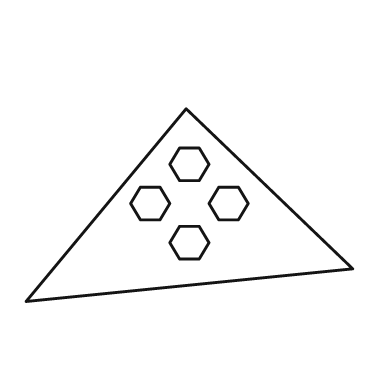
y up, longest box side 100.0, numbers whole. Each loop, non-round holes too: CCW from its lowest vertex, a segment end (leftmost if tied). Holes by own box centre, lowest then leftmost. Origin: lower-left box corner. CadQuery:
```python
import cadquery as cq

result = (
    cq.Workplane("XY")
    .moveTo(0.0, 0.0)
    .lineTo(100.0, 10.0)
    .lineTo(49.0, 59.0)
    .close()
    .moveTo(47.0, 13.0)
    .lineTo(53.0, 13.0)
    .lineTo(56.0, 18.0)
    .lineTo(53.0, 23.0)
    .lineTo(47.0, 23.0)
    .lineTo(44.0, 18.0)
    .close()
    .moveTo(35.0, 25.0)
    .lineTo(41.0, 25.0)
    .lineTo(44.0, 30.0)
    .lineTo(41.0, 35.0)
    .lineTo(35.0, 35.0)
    .lineTo(32.0, 30.0)
    .close()
    .moveTo(59.0, 25.0)
    .lineTo(65.0, 25.0)
    .lineTo(68.0, 30.0)
    .lineTo(65.0, 35.0)
    .lineTo(59.0, 35.0)
    .lineTo(56.0, 30.0)
    .close()
    .moveTo(47.0, 37.0)
    .lineTo(53.0, 37.0)
    .lineTo(56.0, 42.0)
    .lineTo(53.0, 47.0)
    .lineTo(47.0, 47.0)
    .lineTo(44.0, 42.0)
    .close()
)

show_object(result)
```